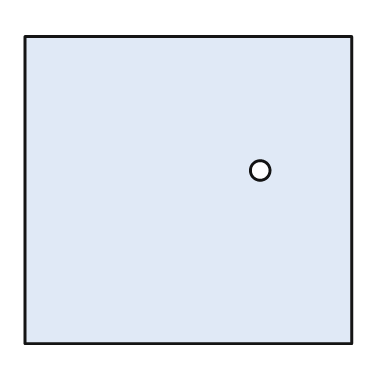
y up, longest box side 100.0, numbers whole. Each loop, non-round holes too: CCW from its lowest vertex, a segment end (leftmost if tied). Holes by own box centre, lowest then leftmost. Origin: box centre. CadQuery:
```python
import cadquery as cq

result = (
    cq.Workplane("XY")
    .moveTo(-50.0, -47.0)
    .lineTo(50.0, -47.0)
    .lineTo(50.0, 47.0)
    .lineTo(-50.0, 47.0)
    .close()
    .moveTo(22.0, 6.0)
    .circle(3.0)
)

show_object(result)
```